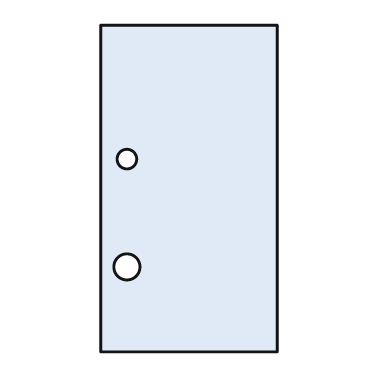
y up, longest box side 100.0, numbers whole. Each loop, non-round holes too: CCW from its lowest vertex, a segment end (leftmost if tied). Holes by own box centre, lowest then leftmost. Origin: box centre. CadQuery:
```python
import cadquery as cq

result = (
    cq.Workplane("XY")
    .moveTo(-27.0, -50.0)
    .lineTo(27.0, -50.0)
    .lineTo(27.0, 50.0)
    .lineTo(-27.0, 50.0)
    .close()
    .moveTo(-19.0, -24.0)
    .circle(4.0)
    .moveTo(-19.0, 9.0)
    .circle(3.0)
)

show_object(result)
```